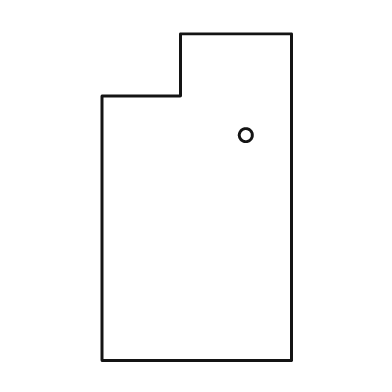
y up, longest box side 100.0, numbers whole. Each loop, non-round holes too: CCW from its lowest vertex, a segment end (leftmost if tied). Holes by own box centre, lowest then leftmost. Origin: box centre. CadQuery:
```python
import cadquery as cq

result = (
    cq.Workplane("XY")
    .moveTo(-29.0, -50.0)
    .lineTo(29.0, -50.0)
    .lineTo(29.0, 50.0)
    .lineTo(-5.0, 50.0)
    .lineTo(-5.0, 31.0)
    .lineTo(-29.0, 31.0)
    .close()
    .moveTo(15.0, 19.0)
    .circle(2.0)
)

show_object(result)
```